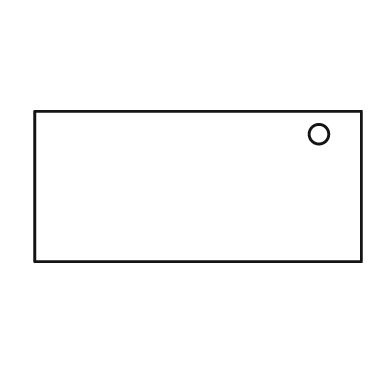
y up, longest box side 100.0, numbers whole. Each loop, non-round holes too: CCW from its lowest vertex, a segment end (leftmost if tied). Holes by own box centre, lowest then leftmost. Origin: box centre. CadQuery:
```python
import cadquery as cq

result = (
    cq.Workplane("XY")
    .moveTo(-50.0, -23.0)
    .lineTo(50.0, -23.0)
    .lineTo(50.0, 23.0)
    .lineTo(-50.0, 23.0)
    .close()
    .moveTo(37.0, 16.0)
    .circle(3.0)
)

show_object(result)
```